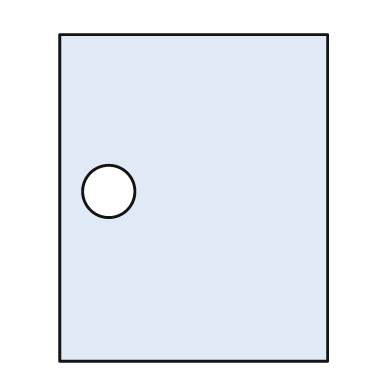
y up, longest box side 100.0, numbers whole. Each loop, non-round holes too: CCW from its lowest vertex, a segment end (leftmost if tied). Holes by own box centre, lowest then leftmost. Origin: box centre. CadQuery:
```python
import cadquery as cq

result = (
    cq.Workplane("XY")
    .moveTo(-41.0, -50.0)
    .lineTo(41.0, -50.0)
    .lineTo(41.0, 50.0)
    .lineTo(-41.0, 50.0)
    .close()
    .moveTo(-26.0, 2.0)
    .circle(8.0)
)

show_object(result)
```